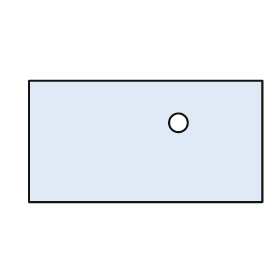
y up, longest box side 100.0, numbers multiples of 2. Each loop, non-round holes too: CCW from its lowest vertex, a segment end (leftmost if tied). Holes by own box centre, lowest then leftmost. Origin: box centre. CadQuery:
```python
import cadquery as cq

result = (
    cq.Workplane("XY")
    .moveTo(-50.0, -26.0)
    .lineTo(50.0, -26.0)
    .lineTo(50.0, 26.0)
    .lineTo(-50.0, 26.0)
    .close()
    .moveTo(14.0, 8.0)
    .circle(4.0)
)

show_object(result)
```